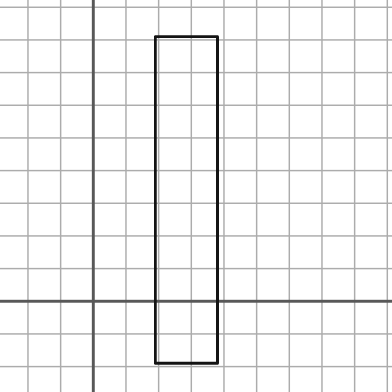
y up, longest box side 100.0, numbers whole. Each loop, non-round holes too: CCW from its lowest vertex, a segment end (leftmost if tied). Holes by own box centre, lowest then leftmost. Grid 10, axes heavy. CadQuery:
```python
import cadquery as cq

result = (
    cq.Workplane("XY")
    .moveTo(19.0, -19.0)
    .lineTo(38.0, -19.0)
    .lineTo(38.0, 81.0)
    .lineTo(19.0, 81.0)
    .close()
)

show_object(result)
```